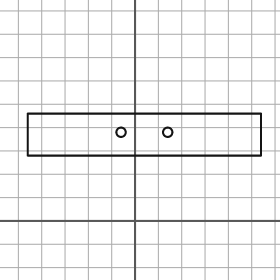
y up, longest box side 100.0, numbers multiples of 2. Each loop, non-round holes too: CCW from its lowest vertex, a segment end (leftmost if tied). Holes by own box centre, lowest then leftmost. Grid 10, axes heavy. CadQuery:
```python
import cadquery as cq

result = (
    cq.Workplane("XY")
    .moveTo(-46.0, 28.0)
    .lineTo(54.0, 28.0)
    .lineTo(54.0, 46.0)
    .lineTo(-46.0, 46.0)
    .close()
    .moveTo(-6.0, 38.0)
    .circle(2.0)
    .moveTo(14.0, 38.0)
    .circle(2.0)
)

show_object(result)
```